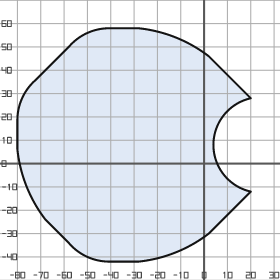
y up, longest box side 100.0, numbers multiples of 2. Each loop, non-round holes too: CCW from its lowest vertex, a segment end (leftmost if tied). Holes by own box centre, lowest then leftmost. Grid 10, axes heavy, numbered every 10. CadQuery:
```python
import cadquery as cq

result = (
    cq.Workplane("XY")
    .moveTo(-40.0, -42.0)
    .lineTo(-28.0, -42.0)
    .threePointArc((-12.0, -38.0), (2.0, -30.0))
    .lineTo(20.0, -12.0)
    .threePointArc((4.0, 8.0), (20.0, 28.0))
    .lineTo(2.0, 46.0)
    .threePointArc((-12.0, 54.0), (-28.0, 58.0))
    .lineTo(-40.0, 58.0)
    .threePointArc((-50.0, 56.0), (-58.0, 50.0))
    .lineTo(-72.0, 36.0)
    .threePointArc((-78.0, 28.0), (-80.0, 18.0))
    .lineTo(-80.0, 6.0)
    .threePointArc((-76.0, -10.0), (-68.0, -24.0))
    .lineTo(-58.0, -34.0)
    .threePointArc((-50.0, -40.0), (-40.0, -42.0))
    .close()
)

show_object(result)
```